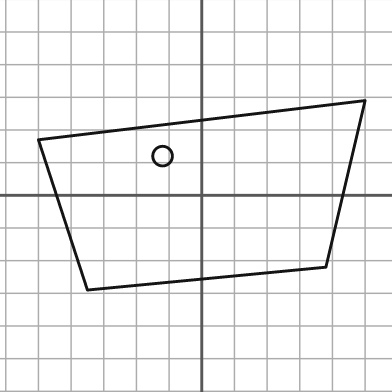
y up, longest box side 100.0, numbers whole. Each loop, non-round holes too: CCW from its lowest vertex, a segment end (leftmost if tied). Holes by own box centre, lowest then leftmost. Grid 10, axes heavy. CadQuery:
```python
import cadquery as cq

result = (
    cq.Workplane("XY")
    .moveTo(-35.0, -29.0)
    .lineTo(38.0, -22.0)
    .lineTo(50.0, 29.0)
    .lineTo(-50.0, 17.0)
    .close()
    .moveTo(-12.0, 12.0)
    .circle(3.0)
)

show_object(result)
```